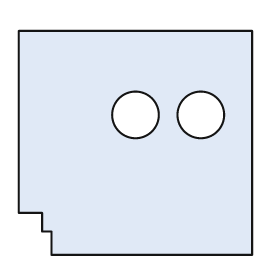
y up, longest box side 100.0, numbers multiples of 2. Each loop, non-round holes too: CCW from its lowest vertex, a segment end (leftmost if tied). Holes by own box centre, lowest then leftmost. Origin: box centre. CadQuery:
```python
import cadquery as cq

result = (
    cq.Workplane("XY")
    .moveTo(-36.0, -48.0)
    .lineTo(50.0, -48.0)
    .lineTo(50.0, 48.0)
    .lineTo(-50.0, 48.0)
    .lineTo(-50.0, -30.0)
    .lineTo(-40.0, -30.0)
    .lineTo(-40.0, -38.0)
    .lineTo(-36.0, -38.0)
    .close()
    .moveTo(0.0, 12.0)
    .circle(10.0)
    .moveTo(28.0, 12.0)
    .circle(10.0)
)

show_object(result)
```